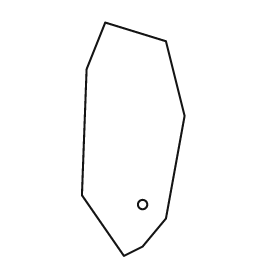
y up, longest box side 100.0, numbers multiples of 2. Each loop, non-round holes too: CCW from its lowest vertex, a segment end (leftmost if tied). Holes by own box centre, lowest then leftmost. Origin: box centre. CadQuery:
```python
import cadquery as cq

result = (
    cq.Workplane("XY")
    .moveTo(-4.0, -50.0)
    .lineTo(4.0, -46.0)
    .lineTo(14.0, -34.0)
    .lineTo(22.0, 10.0)
    .lineTo(14.0, 42.0)
    .lineTo(-12.0, 50.0)
    .lineTo(-20.0, 30.0)
    .lineTo(-22.0, -24.0)
    .close()
    .moveTo(4.0, -28.0)
    .circle(2.0)
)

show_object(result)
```